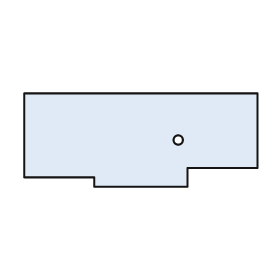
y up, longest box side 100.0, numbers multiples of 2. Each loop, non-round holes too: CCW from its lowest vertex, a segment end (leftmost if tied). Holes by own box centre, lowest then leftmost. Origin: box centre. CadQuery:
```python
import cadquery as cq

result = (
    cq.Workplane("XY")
    .moveTo(-20.0, -20.0)
    .lineTo(20.0, -20.0)
    .lineTo(20.0, -12.0)
    .lineTo(50.0, -12.0)
    .lineTo(50.0, 20.0)
    .lineTo(-50.0, 20.0)
    .lineTo(-50.0, -16.0)
    .lineTo(-20.0, -16.0)
    .close()
    .moveTo(16.0, 0.0)
    .circle(2.0)
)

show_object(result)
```